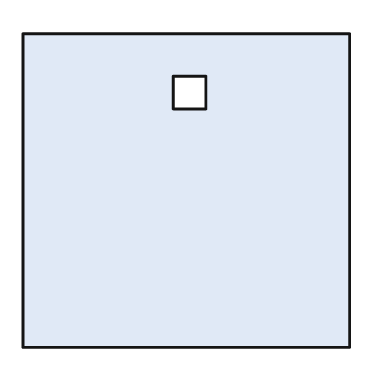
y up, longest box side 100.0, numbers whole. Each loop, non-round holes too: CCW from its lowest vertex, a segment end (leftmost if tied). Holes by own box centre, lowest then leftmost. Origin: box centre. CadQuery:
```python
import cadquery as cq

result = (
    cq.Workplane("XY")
    .moveTo(-50.0, -48.0)
    .lineTo(50.0, -48.0)
    .lineTo(50.0, 48.0)
    .lineTo(-50.0, 48.0)
    .close()
    .moveTo(-4.0, 25.0)
    .lineTo(6.0, 25.0)
    .lineTo(6.0, 35.0)
    .lineTo(-4.0, 35.0)
    .close()
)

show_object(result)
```